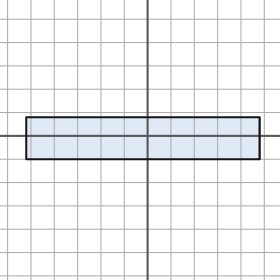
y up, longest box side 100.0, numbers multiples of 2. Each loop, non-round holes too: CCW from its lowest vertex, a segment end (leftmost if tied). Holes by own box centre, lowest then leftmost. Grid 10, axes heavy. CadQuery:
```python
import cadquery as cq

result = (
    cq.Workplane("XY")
    .moveTo(-52.0, -10.0)
    .lineTo(48.0, -10.0)
    .lineTo(48.0, 8.0)
    .lineTo(-52.0, 8.0)
    .close()
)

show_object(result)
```